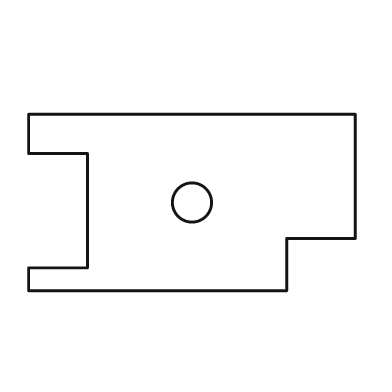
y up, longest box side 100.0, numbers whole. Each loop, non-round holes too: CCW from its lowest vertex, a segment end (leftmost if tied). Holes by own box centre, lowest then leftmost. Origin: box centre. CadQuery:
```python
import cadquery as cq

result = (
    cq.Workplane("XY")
    .moveTo(-50.0, -27.0)
    .lineTo(29.0, -27.0)
    .lineTo(29.0, -11.0)
    .lineTo(50.0, -11.0)
    .lineTo(50.0, 27.0)
    .lineTo(-50.0, 27.0)
    .lineTo(-50.0, 15.0)
    .lineTo(-32.0, 15.0)
    .lineTo(-32.0, -20.0)
    .lineTo(-50.0, -20.0)
    .close()
    .moveTo(0.0, 0.0)
    .circle(6.0)
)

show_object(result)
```